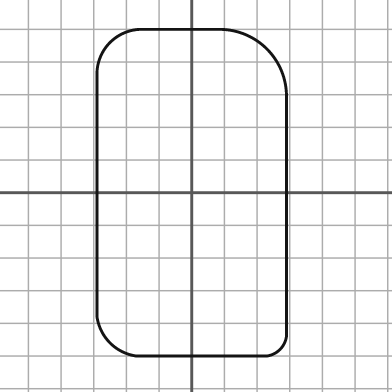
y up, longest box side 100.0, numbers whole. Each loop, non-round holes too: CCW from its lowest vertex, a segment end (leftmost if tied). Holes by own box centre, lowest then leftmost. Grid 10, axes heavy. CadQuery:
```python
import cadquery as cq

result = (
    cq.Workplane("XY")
    .moveTo(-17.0, -50.0)
    .lineTo(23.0, -50.0)
    .threePointArc((27.0, -48.0), (29.0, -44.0))
    .lineTo(29.0, 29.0)
    .threePointArc((23.0, 44.0), (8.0, 50.0))
    .lineTo(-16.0, 50.0)
    .threePointArc((-25.0, 46.0), (-29.0, 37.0))
    .lineTo(-29.0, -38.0)
    .threePointArc((-25.0, -46.0), (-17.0, -50.0))
    .close()
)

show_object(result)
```